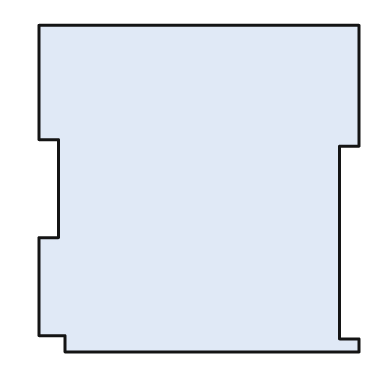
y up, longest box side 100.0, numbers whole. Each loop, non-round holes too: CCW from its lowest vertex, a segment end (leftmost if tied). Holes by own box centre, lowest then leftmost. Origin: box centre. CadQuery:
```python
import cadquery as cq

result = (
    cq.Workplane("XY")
    .moveTo(-41.0, -50.0)
    .lineTo(49.0, -50.0)
    .lineTo(49.0, -46.0)
    .lineTo(43.0, -46.0)
    .lineTo(43.0, 13.0)
    .lineTo(49.0, 13.0)
    .lineTo(49.0, 50.0)
    .lineTo(-49.0, 50.0)
    .lineTo(-49.0, 15.0)
    .lineTo(-43.0, 15.0)
    .lineTo(-43.0, -15.0)
    .lineTo(-49.0, -15.0)
    .lineTo(-49.0, -45.0)
    .lineTo(-41.0, -45.0)
    .close()
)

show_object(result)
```